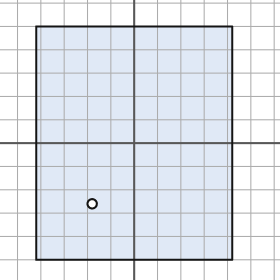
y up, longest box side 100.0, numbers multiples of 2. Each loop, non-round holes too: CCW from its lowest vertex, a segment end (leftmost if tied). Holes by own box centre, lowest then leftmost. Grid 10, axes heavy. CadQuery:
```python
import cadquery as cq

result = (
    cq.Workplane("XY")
    .moveTo(-42.0, -50.0)
    .lineTo(42.0, -50.0)
    .lineTo(42.0, 50.0)
    .lineTo(-42.0, 50.0)
    .close()
    .moveTo(-18.0, -26.0)
    .circle(2.0)
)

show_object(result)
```